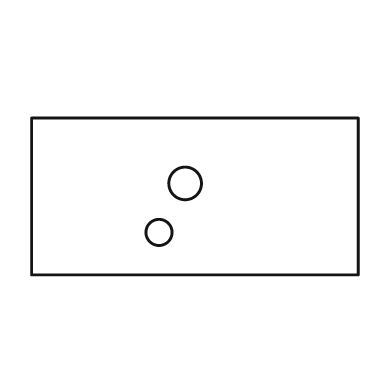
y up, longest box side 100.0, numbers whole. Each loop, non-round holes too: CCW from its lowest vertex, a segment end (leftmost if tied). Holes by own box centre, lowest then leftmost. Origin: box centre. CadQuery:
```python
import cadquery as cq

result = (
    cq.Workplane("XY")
    .moveTo(-50.0, -24.0)
    .lineTo(50.0, -24.0)
    .lineTo(50.0, 24.0)
    .lineTo(-50.0, 24.0)
    .close()
    .moveTo(-11.0, -11.0)
    .circle(4.0)
    .moveTo(-3.0, 4.0)
    .circle(5.0)
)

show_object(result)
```